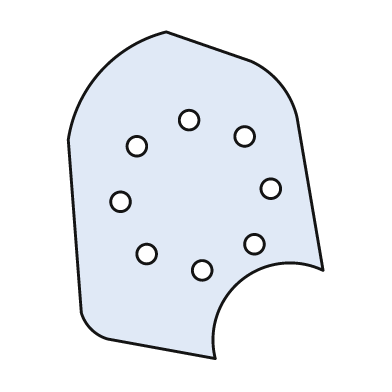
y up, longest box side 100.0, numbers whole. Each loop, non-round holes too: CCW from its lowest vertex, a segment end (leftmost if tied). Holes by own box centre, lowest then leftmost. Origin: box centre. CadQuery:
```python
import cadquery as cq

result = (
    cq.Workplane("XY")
    .moveTo(6.0, -50.0)
    .threePointArc((14.0, -26.0), (39.0, -23.0))
    .lineTo(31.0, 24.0)
    .threePointArc((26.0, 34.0), (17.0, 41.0))
    .lineTo(-9.0, 50.0)
    .threePointArc((-29.0, 38.0), (-39.0, 17.0))
    .lineTo(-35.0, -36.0)
    .threePointArc((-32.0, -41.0), (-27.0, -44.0))
    .close()
    .moveTo(2.0, -23.0)
    .circle(3.0)
    .moveTo(-15.0, -18.0)
    .circle(3.0)
    .moveTo(18.0, -15.0)
    .circle(3.0)
    .moveTo(-23.0, -2.0)
    .circle(3.0)
    .moveTo(23.0, 2.0)
    .circle(3.0)
    .moveTo(-18.0, 15.0)
    .circle(3.0)
    .moveTo(15.0, 18.0)
    .circle(3.0)
    .moveTo(-2.0, 23.0)
    .circle(3.0)
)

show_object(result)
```